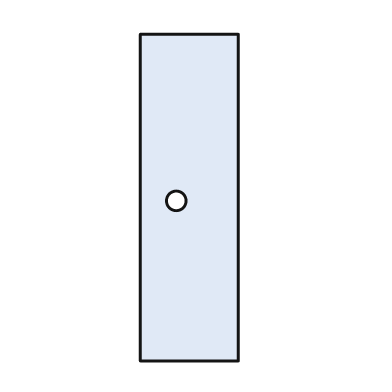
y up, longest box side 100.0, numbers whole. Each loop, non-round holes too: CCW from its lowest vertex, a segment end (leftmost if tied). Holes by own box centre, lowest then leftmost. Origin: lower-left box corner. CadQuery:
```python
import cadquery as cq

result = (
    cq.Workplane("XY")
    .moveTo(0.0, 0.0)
    .lineTo(30.0, 0.0)
    .lineTo(30.0, 100.0)
    .lineTo(0.0, 100.0)
    .close()
    .moveTo(11.0, 49.0)
    .circle(3.0)
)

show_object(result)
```